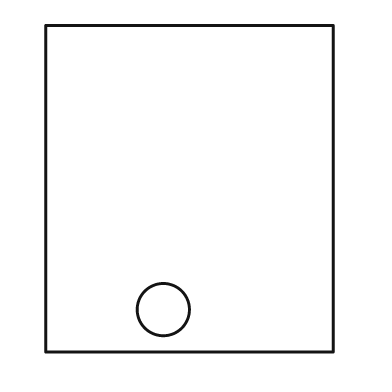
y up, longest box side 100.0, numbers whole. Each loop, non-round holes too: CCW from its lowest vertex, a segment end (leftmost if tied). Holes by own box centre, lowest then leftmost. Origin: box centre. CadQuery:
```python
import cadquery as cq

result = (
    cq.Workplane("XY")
    .moveTo(-44.0, -50.0)
    .lineTo(44.0, -50.0)
    .lineTo(44.0, 50.0)
    .lineTo(-44.0, 50.0)
    .close()
    .moveTo(-8.0, -37.0)
    .circle(8.0)
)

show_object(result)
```